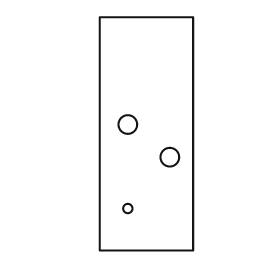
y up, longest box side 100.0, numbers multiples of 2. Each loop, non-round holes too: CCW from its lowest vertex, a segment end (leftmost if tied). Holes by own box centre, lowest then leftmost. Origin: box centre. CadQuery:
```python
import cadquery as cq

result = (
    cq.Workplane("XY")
    .moveTo(-20.0, -50.0)
    .lineTo(20.0, -50.0)
    .lineTo(20.0, 50.0)
    .lineTo(-20.0, 50.0)
    .close()
    .moveTo(-8.0, -32.0)
    .circle(2.0)
    .moveTo(10.0, -10.0)
    .circle(4.0)
    .moveTo(-8.0, 4.0)
    .circle(4.0)
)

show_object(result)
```